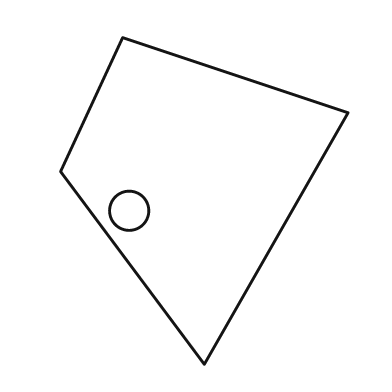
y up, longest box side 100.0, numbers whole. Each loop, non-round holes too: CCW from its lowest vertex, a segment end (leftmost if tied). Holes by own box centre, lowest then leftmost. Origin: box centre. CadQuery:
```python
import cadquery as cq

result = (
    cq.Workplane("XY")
    .moveTo(0.0, -50.0)
    .lineTo(44.0, 27.0)
    .lineTo(-25.0, 50.0)
    .lineTo(-44.0, 9.0)
    .close()
    .moveTo(-23.0, -3.0)
    .circle(6.0)
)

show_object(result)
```